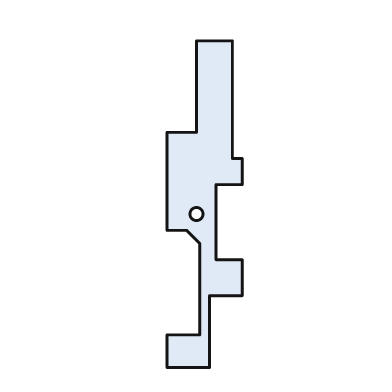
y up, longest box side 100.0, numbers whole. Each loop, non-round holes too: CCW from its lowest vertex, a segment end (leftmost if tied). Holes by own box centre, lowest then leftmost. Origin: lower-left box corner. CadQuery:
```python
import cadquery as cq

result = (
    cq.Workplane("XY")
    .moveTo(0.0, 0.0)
    .lineTo(13.0, 0.0)
    .lineTo(13.0, 22.0)
    .lineTo(23.0, 22.0)
    .lineTo(23.0, 33.0)
    .lineTo(15.0, 33.0)
    .lineTo(15.0, 56.0)
    .lineTo(23.0, 56.0)
    .lineTo(23.0, 64.0)
    .lineTo(20.0, 64.0)
    .lineTo(20.0, 100.0)
    .lineTo(9.0, 100.0)
    .lineTo(9.0, 72.0)
    .lineTo(0.0, 72.0)
    .lineTo(0.0, 42.0)
    .lineTo(6.0, 42.0)
    .lineTo(10.0, 38.0)
    .lineTo(10.0, 10.0)
    .lineTo(0.0, 10.0)
    .close()
    .moveTo(9.0, 47.0)
    .circle(2.0)
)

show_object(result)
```